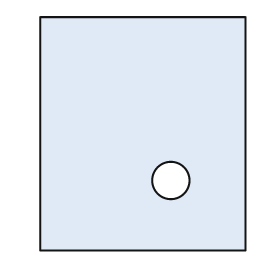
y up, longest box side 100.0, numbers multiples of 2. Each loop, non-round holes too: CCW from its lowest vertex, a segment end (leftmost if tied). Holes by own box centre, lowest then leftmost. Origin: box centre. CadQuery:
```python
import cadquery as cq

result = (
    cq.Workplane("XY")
    .moveTo(-44.0, -50.0)
    .lineTo(44.0, -50.0)
    .lineTo(44.0, 50.0)
    .lineTo(-44.0, 50.0)
    .close()
    .moveTo(12.0, -20.0)
    .circle(8.0)
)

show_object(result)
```